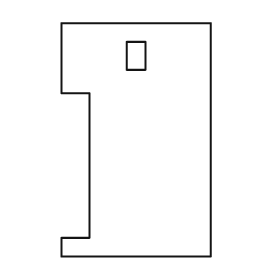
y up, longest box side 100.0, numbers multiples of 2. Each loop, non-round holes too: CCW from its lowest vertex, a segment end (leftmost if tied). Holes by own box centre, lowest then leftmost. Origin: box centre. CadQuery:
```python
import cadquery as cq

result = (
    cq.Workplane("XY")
    .moveTo(-32.0, -50.0)
    .lineTo(32.0, -50.0)
    .lineTo(32.0, 50.0)
    .lineTo(-32.0, 50.0)
    .lineTo(-32.0, 20.0)
    .lineTo(-20.0, 20.0)
    .lineTo(-20.0, -42.0)
    .lineTo(-32.0, -42.0)
    .close()
    .moveTo(-4.0, 30.0)
    .lineTo(4.0, 30.0)
    .lineTo(4.0, 42.0)
    .lineTo(-4.0, 42.0)
    .close()
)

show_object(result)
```